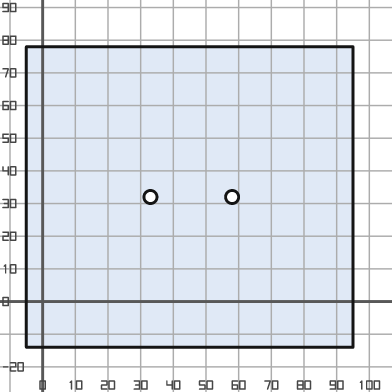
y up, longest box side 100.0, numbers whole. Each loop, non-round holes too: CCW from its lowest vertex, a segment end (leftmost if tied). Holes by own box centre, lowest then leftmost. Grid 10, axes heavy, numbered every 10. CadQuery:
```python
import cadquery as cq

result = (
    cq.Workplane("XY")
    .moveTo(-5.0, -14.0)
    .lineTo(95.0, -14.0)
    .lineTo(95.0, 78.0)
    .lineTo(-5.0, 78.0)
    .close()
    .moveTo(33.0, 32.0)
    .circle(2.0)
    .moveTo(58.0, 32.0)
    .circle(2.0)
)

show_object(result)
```